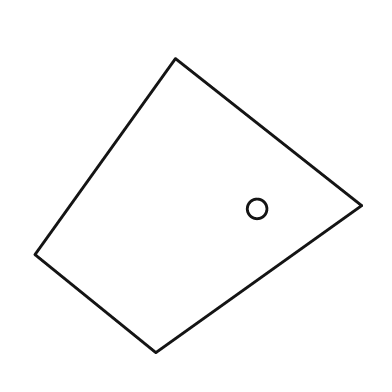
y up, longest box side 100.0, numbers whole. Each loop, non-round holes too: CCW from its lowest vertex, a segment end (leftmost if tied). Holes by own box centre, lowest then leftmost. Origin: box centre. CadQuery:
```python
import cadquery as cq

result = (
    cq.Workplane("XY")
    .moveTo(-13.0, -45.0)
    .lineTo(50.0, 0.0)
    .lineTo(-7.0, 45.0)
    .lineTo(-50.0, -15.0)
    .close()
    .moveTo(18.0, -1.0)
    .circle(3.0)
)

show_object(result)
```